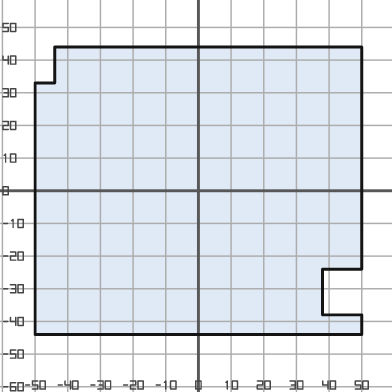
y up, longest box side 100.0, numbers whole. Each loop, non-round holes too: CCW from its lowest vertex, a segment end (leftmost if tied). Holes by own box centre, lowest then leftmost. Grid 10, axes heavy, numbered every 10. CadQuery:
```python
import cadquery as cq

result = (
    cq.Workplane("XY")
    .moveTo(-50.0, -44.0)
    .lineTo(50.0, -44.0)
    .lineTo(50.0, -38.0)
    .lineTo(38.0, -38.0)
    .lineTo(38.0, -24.0)
    .lineTo(50.0, -24.0)
    .lineTo(50.0, 44.0)
    .lineTo(-44.0, 44.0)
    .lineTo(-44.0, 33.0)
    .lineTo(-50.0, 33.0)
    .close()
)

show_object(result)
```